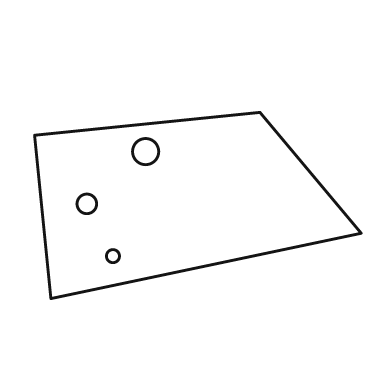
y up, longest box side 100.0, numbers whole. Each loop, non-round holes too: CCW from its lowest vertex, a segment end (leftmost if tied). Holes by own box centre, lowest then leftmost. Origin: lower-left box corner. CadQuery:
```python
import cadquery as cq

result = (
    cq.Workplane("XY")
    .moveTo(5.0, 0.0)
    .lineTo(100.0, 20.0)
    .lineTo(69.0, 57.0)
    .lineTo(0.0, 50.0)
    .close()
    .moveTo(24.0, 13.0)
    .circle(2.0)
    .moveTo(16.0, 29.0)
    .circle(3.0)
    .moveTo(34.0, 45.0)
    .circle(4.0)
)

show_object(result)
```